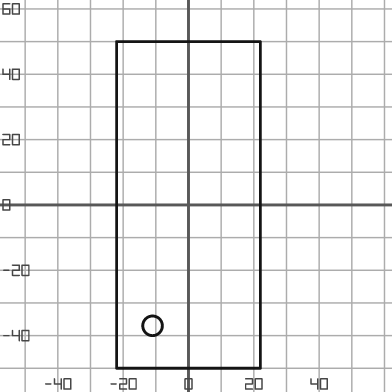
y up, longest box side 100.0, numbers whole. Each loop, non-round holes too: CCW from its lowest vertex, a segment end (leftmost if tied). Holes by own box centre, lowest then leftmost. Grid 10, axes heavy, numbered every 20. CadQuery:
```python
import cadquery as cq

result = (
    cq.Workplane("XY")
    .moveTo(-22.0, -50.0)
    .lineTo(22.0, -50.0)
    .lineTo(22.0, 50.0)
    .lineTo(-22.0, 50.0)
    .close()
    .moveTo(-11.0, -37.0)
    .circle(3.0)
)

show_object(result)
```